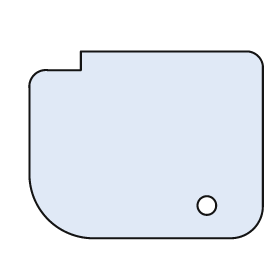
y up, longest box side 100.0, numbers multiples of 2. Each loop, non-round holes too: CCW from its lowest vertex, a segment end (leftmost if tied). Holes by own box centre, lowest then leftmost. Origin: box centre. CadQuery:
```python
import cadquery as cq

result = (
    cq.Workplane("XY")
    .moveTo(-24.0, -40.0)
    .lineTo(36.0, -40.0)
    .threePointArc((46.0, -36.0), (50.0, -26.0))
    .lineTo(50.0, 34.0)
    .threePointArc((48.0, 38.0), (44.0, 40.0))
    .lineTo(-28.0, 40.0)
    .lineTo(-28.0, 32.0)
    .lineTo(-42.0, 32.0)
    .threePointArc((-48.0, 30.0), (-50.0, 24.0))
    .lineTo(-50.0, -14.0)
    .threePointArc((-42.0, -32.0), (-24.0, -40.0))
    .close()
    .moveTo(26.0, -26.0)
    .circle(4.0)
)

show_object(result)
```